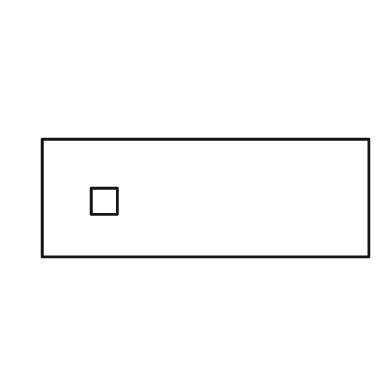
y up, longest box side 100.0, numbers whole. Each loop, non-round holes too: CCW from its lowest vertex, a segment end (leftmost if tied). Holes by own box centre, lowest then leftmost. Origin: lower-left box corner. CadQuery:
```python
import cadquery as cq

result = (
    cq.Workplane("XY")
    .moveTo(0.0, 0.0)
    .lineTo(100.0, 0.0)
    .lineTo(100.0, 36.0)
    .lineTo(0.0, 36.0)
    .close()
    .moveTo(15.0, 13.0)
    .lineTo(23.0, 13.0)
    .lineTo(23.0, 21.0)
    .lineTo(15.0, 21.0)
    .close()
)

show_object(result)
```